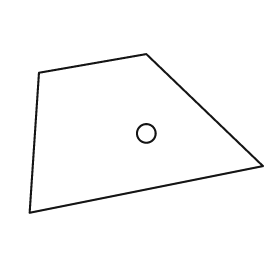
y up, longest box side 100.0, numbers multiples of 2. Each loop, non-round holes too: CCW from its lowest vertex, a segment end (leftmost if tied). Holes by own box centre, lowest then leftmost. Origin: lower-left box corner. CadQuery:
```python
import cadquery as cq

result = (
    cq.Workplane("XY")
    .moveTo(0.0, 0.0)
    .lineTo(100.0, 20.0)
    .lineTo(50.0, 68.0)
    .lineTo(4.0, 60.0)
    .close()
    .moveTo(50.0, 34.0)
    .circle(4.0)
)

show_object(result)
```